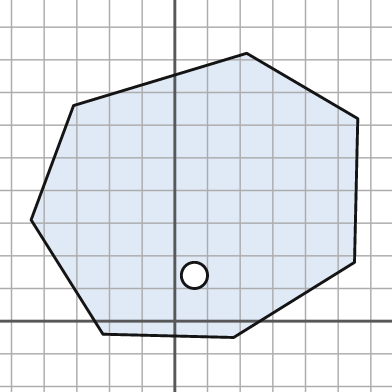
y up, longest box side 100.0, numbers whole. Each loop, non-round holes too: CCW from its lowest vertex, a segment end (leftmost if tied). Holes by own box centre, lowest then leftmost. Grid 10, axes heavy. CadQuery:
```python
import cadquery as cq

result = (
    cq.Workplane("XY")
    .moveTo(18.0, -5.0)
    .lineTo(55.0, 18.0)
    .lineTo(56.0, 62.0)
    .lineTo(22.0, 82.0)
    .lineTo(-31.0, 66.0)
    .lineTo(-44.0, 31.0)
    .lineTo(-22.0, -4.0)
    .close()
    .moveTo(6.0, 14.0)
    .circle(4.0)
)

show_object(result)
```